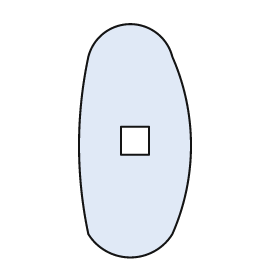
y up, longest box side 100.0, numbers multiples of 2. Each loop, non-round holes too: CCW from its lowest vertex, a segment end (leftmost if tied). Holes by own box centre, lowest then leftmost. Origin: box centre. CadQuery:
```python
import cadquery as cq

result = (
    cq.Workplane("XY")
    .moveTo(-20.0, -40.0)
    .threePointArc((-2.0, -50.0), (16.0, -40.0))
    .threePointArc((24.0, -2.0), (16.0, 36.0))
    .threePointArc((-2.0, 50.0), (-20.0, 36.0))
    .threePointArc((-24.0, -2.0), (-20.0, -40.0))
    .close()
    .moveTo(-6.0, -6.0)
    .lineTo(6.0, -6.0)
    .lineTo(6.0, 6.0)
    .lineTo(-6.0, 6.0)
    .close()
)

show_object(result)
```